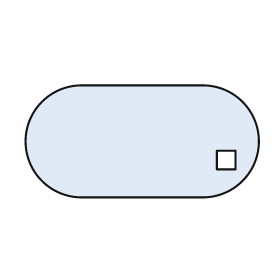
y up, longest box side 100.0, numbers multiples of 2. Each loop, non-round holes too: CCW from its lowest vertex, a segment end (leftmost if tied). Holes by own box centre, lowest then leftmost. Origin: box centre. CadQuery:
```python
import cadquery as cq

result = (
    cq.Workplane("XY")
    .moveTo(-26.0, -24.0)
    .lineTo(26.0, -24.0)
    .threePointArc((50.0, 0.0), (26.0, 24.0))
    .lineTo(-26.0, 24.0)
    .threePointArc((-50.0, 0.0), (-26.0, -24.0))
    .close()
    .moveTo(32.0, -12.0)
    .lineTo(40.0, -12.0)
    .lineTo(40.0, -4.0)
    .lineTo(32.0, -4.0)
    .close()
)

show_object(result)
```